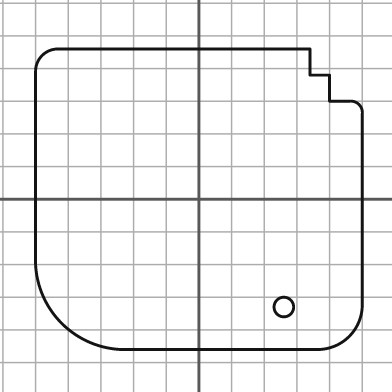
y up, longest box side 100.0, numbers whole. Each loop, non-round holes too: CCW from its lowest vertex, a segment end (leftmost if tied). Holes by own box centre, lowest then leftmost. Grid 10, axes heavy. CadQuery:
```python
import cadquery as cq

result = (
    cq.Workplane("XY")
    .moveTo(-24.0, -46.0)
    .lineTo(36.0, -46.0)
    .threePointArc((46.0, -42.0), (50.0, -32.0))
    .lineTo(50.0, 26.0)
    .threePointArc((49.0, 29.0), (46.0, 30.0))
    .lineTo(40.0, 30.0)
    .lineTo(40.0, 38.0)
    .lineTo(34.0, 38.0)
    .lineTo(34.0, 46.0)
    .lineTo(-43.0, 46.0)
    .threePointArc((-48.0, 44.0), (-50.0, 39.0))
    .lineTo(-50.0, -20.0)
    .threePointArc((-42.0, -38.0), (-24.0, -46.0))
    .close()
    .moveTo(26.0, -33.0)
    .circle(3.0)
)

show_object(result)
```